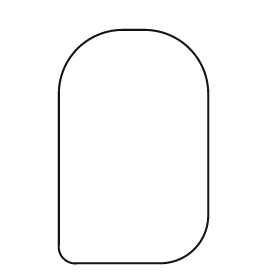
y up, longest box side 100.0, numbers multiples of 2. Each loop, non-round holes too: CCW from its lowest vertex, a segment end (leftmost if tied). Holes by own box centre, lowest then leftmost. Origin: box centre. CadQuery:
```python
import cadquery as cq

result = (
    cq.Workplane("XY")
    .moveTo(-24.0, -50.0)
    .lineTo(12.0, -50.0)
    .threePointArc((26.0, -44.0), (32.0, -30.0))
    .lineTo(32.0, 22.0)
    .threePointArc((24.0, 42.0), (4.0, 50.0))
    .lineTo(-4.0, 50.0)
    .threePointArc((-24.0, 42.0), (-32.0, 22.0))
    .lineTo(-32.0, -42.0)
    .threePointArc((-30.0, -48.0), (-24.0, -50.0))
    .close()
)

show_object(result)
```